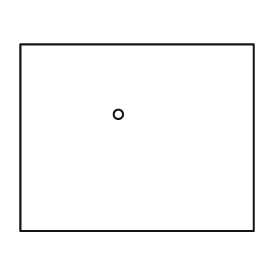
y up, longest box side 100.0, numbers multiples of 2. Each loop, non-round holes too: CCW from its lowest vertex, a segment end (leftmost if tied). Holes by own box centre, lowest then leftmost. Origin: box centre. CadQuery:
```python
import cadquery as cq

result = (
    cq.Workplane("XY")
    .moveTo(-50.0, -40.0)
    .lineTo(50.0, -40.0)
    .lineTo(50.0, 40.0)
    .lineTo(-50.0, 40.0)
    .close()
    .moveTo(-8.0, 10.0)
    .circle(2.0)
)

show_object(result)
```